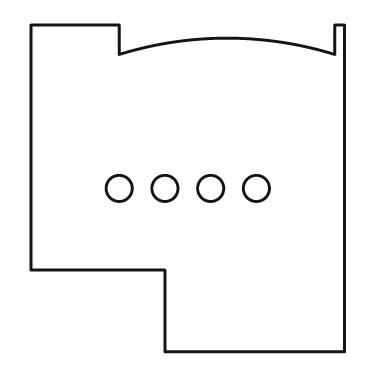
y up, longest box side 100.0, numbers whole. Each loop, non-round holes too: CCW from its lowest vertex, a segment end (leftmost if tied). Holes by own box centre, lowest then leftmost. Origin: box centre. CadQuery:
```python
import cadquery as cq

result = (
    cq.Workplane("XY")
    .moveTo(-7.0, -50.0)
    .lineTo(48.0, -50.0)
    .lineTo(48.0, 50.0)
    .lineTo(45.0, 50.0)
    .lineTo(45.0, 41.0)
    .threePointArc((12.0, 46.0), (-21.0, 41.0))
    .lineTo(-21.0, 50.0)
    .lineTo(-48.0, 50.0)
    .lineTo(-48.0, -25.0)
    .lineTo(-7.0, -25.0)
    .close()
    .moveTo(-21.0, 0.0)
    .circle(4.0)
    .moveTo(-7.0, 0.0)
    .circle(4.0)
    .moveTo(7.0, 0.0)
    .circle(4.0)
    .moveTo(21.0, 0.0)
    .circle(4.0)
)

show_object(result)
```